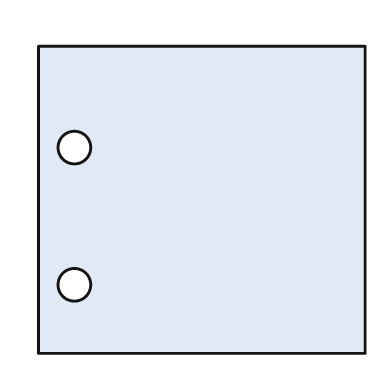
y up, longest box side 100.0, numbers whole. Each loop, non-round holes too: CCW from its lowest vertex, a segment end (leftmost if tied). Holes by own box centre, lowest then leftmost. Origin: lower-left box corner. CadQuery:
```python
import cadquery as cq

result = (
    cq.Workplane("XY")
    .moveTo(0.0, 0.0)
    .lineTo(100.0, 0.0)
    .lineTo(100.0, 94.0)
    .lineTo(0.0, 94.0)
    .close()
    .moveTo(11.0, 21.0)
    .circle(5.0)
    .moveTo(11.0, 63.0)
    .circle(5.0)
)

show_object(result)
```